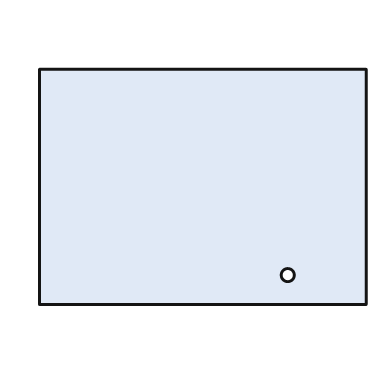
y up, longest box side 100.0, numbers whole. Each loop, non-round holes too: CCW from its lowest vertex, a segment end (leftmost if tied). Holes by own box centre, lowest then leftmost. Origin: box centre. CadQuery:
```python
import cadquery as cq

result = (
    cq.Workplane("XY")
    .moveTo(-50.0, -36.0)
    .lineTo(50.0, -36.0)
    .lineTo(50.0, 36.0)
    .lineTo(-50.0, 36.0)
    .close()
    .moveTo(26.0, -27.0)
    .circle(2.0)
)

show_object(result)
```